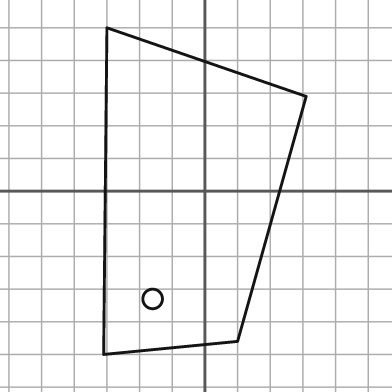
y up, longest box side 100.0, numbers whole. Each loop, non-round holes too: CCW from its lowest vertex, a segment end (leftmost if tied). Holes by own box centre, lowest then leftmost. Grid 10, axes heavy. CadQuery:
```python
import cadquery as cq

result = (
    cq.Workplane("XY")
    .moveTo(-31.0, -50.0)
    .lineTo(10.0, -46.0)
    .lineTo(31.0, 29.0)
    .lineTo(-30.0, 50.0)
    .close()
    .moveTo(-16.0, -33.0)
    .circle(3.0)
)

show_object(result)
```